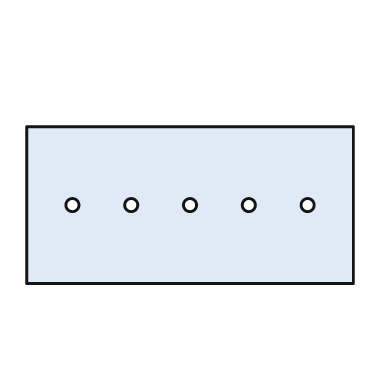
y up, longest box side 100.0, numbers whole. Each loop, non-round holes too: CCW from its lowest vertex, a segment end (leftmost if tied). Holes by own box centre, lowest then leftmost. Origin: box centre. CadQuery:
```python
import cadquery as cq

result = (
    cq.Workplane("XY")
    .moveTo(-50.0, -24.0)
    .lineTo(50.0, -24.0)
    .lineTo(50.0, 24.0)
    .lineTo(-50.0, 24.0)
    .close()
    .moveTo(-36.0, 0.0)
    .circle(2.0)
    .moveTo(-18.0, 0.0)
    .circle(2.0)
    .moveTo(0.0, 0.0)
    .circle(2.0)
    .moveTo(18.0, 0.0)
    .circle(2.0)
    .moveTo(36.0, 0.0)
    .circle(2.0)
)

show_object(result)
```